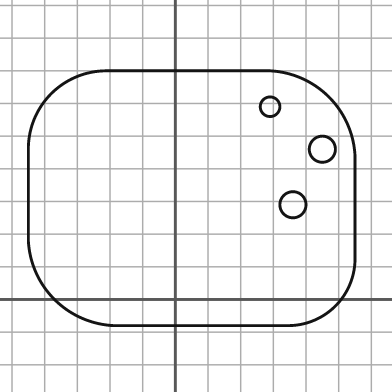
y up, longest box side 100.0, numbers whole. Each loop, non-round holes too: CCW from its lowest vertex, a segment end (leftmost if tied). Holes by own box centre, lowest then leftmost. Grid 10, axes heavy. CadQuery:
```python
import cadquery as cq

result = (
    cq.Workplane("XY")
    .moveTo(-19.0, -8.0)
    .lineTo(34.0, -8.0)
    .threePointArc((49.0, -2.0), (55.0, 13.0))
    .lineTo(55.0, 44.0)
    .threePointArc((47.0, 62.0), (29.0, 70.0))
    .lineTo(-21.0, 70.0)
    .threePointArc((-38.0, 63.0), (-45.0, 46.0))
    .lineTo(-45.0, 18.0)
    .threePointArc((-37.0, 0.0), (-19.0, -8.0))
    .close()
    .moveTo(36.0, 29.0)
    .circle(4.0)
    .moveTo(45.0, 46.0)
    .circle(4.0)
    .moveTo(29.0, 59.0)
    .circle(3.0)
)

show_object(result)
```